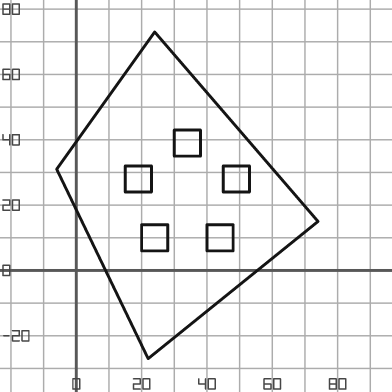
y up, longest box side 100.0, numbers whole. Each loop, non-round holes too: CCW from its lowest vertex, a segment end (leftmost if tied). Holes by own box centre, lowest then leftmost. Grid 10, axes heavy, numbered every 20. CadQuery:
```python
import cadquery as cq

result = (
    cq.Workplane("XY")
    .moveTo(22.0, -27.0)
    .lineTo(74.0, 15.0)
    .lineTo(24.0, 73.0)
    .lineTo(-6.0, 31.0)
    .close()
    .moveTo(20.0, 6.0)
    .lineTo(28.0, 6.0)
    .lineTo(28.0, 14.0)
    .lineTo(20.0, 14.0)
    .close()
    .moveTo(40.0, 6.0)
    .lineTo(48.0, 6.0)
    .lineTo(48.0, 14.0)
    .lineTo(40.0, 14.0)
    .close()
    .moveTo(15.0, 24.0)
    .lineTo(23.0, 24.0)
    .lineTo(23.0, 32.0)
    .lineTo(15.0, 32.0)
    .close()
    .moveTo(45.0, 24.0)
    .lineTo(53.0, 24.0)
    .lineTo(53.0, 32.0)
    .lineTo(45.0, 32.0)
    .close()
    .moveTo(30.0, 35.0)
    .lineTo(38.0, 35.0)
    .lineTo(38.0, 43.0)
    .lineTo(30.0, 43.0)
    .close()
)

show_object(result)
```